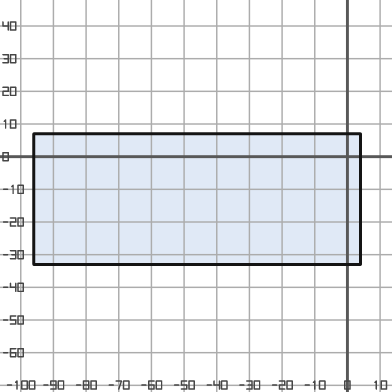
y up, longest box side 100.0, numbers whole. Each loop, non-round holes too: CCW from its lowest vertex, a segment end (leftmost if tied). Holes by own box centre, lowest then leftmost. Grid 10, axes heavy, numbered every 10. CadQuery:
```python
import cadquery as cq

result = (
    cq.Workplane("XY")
    .moveTo(-96.0, -33.0)
    .lineTo(4.0, -33.0)
    .lineTo(4.0, 7.0)
    .lineTo(-96.0, 7.0)
    .close()
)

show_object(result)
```